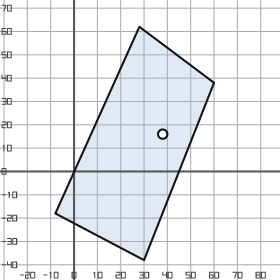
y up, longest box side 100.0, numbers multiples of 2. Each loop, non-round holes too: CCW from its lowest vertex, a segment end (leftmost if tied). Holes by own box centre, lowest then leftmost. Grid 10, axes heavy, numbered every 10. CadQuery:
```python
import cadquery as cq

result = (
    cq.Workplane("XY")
    .moveTo(30.0, -38.0)
    .lineTo(60.0, 38.0)
    .lineTo(28.0, 62.0)
    .lineTo(-8.0, -18.0)
    .close()
    .moveTo(38.0, 16.0)
    .circle(2.0)
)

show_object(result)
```